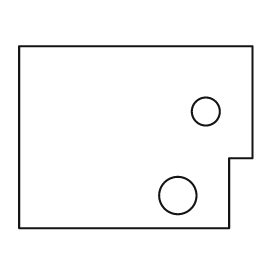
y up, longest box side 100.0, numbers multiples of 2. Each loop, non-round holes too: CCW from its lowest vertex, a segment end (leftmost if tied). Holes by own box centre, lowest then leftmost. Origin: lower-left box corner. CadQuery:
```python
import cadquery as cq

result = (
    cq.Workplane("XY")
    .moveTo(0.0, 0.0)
    .lineTo(90.0, 0.0)
    .lineTo(90.0, 30.0)
    .lineTo(100.0, 30.0)
    .lineTo(100.0, 78.0)
    .lineTo(0.0, 78.0)
    .close()
    .moveTo(68.0, 14.0)
    .circle(8.0)
    .moveTo(80.0, 50.0)
    .circle(6.0)
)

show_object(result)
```